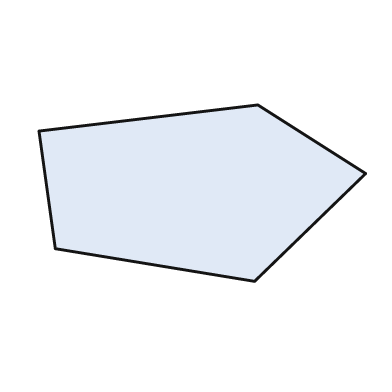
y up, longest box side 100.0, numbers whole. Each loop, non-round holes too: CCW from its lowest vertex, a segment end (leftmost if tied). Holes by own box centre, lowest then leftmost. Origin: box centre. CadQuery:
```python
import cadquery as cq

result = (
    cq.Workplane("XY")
    .moveTo(16.0, -27.0)
    .lineTo(50.0, 6.0)
    .lineTo(17.0, 27.0)
    .lineTo(-50.0, 19.0)
    .lineTo(-45.0, -17.0)
    .close()
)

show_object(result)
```